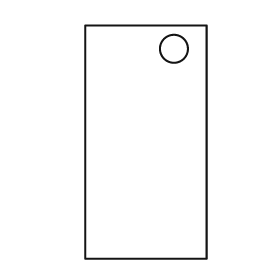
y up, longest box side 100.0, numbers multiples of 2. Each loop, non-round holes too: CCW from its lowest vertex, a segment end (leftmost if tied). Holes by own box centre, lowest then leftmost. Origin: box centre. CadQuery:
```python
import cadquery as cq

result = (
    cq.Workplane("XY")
    .moveTo(-26.0, -50.0)
    .lineTo(26.0, -50.0)
    .lineTo(26.0, 50.0)
    .lineTo(-26.0, 50.0)
    .close()
    .moveTo(12.0, 40.0)
    .circle(6.0)
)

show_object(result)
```